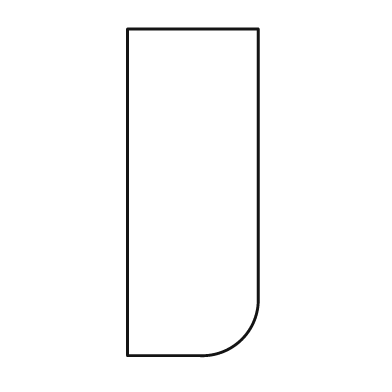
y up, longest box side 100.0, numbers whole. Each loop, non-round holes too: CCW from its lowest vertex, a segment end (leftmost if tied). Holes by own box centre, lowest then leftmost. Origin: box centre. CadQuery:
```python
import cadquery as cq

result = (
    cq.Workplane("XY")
    .moveTo(-20.0, -50.0)
    .lineTo(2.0, -50.0)
    .threePointArc((15.0, -45.0), (20.0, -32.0))
    .lineTo(20.0, 50.0)
    .lineTo(-20.0, 50.0)
    .close()
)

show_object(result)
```